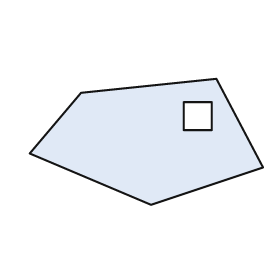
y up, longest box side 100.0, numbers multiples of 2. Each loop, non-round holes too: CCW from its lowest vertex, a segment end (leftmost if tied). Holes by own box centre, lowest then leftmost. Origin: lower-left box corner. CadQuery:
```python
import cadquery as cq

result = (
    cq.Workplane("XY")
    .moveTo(52.0, 0.0)
    .lineTo(100.0, 16.0)
    .lineTo(80.0, 54.0)
    .lineTo(22.0, 48.0)
    .lineTo(0.0, 22.0)
    .close()
    .moveTo(66.0, 32.0)
    .lineTo(78.0, 32.0)
    .lineTo(78.0, 44.0)
    .lineTo(66.0, 44.0)
    .close()
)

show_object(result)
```